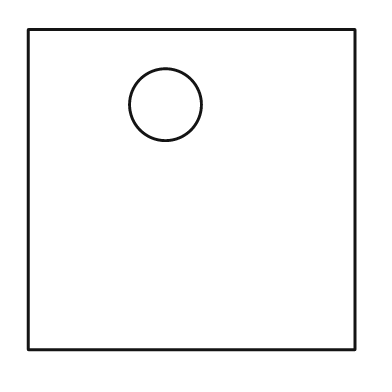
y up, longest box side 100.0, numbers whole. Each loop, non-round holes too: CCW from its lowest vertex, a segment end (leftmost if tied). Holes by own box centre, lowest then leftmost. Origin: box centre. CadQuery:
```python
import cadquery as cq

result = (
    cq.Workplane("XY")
    .moveTo(-50.0, -49.0)
    .lineTo(50.0, -49.0)
    .lineTo(50.0, 49.0)
    .lineTo(-50.0, 49.0)
    .close()
    .moveTo(-8.0, 26.0)
    .circle(11.0)
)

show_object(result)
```